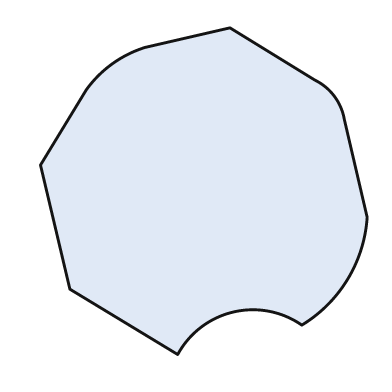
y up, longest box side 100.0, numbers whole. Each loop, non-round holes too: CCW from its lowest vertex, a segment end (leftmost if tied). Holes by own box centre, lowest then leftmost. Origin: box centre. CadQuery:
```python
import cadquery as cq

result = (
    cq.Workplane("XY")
    .moveTo(-8.0, -50.0)
    .threePointArc((9.0, -37.0), (30.0, -41.0))
    .threePointArc((44.0, -27.0), (50.0, -8.0))
    .lineTo(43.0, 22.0)
    .threePointArc((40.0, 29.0), (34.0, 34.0))
    .lineTo(8.0, 50.0)
    .lineTo(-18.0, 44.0)
    .threePointArc((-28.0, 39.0), (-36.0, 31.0))
    .lineTo(-50.0, 8.0)
    .lineTo(-41.0, -30.0)
    .close()
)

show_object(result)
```